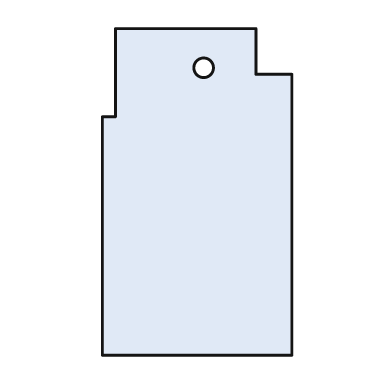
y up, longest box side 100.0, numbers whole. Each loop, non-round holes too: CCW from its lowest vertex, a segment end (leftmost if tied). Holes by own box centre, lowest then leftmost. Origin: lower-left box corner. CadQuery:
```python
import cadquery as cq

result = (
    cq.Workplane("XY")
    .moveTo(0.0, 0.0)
    .lineTo(58.0, 0.0)
    .lineTo(58.0, 86.0)
    .lineTo(47.0, 86.0)
    .lineTo(47.0, 100.0)
    .lineTo(4.0, 100.0)
    .lineTo(4.0, 73.0)
    .lineTo(0.0, 73.0)
    .close()
    .moveTo(31.0, 88.0)
    .circle(3.0)
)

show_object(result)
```